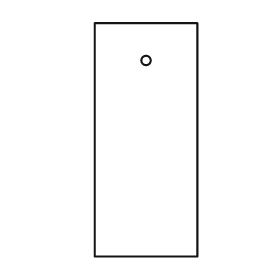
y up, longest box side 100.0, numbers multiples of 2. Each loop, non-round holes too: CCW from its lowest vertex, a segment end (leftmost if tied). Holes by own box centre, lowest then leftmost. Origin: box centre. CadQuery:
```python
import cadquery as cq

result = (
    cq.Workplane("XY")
    .moveTo(-22.0, -50.0)
    .lineTo(22.0, -50.0)
    .lineTo(22.0, 50.0)
    .lineTo(-22.0, 50.0)
    .close()
    .moveTo(0.0, 34.0)
    .circle(2.0)
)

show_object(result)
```